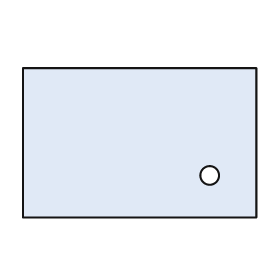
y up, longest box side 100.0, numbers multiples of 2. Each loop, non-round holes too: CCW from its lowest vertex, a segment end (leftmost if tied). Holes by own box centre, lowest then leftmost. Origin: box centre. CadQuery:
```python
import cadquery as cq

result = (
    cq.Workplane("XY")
    .moveTo(-50.0, -32.0)
    .lineTo(50.0, -32.0)
    .lineTo(50.0, 32.0)
    .lineTo(-50.0, 32.0)
    .close()
    .moveTo(30.0, -14.0)
    .circle(4.0)
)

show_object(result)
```